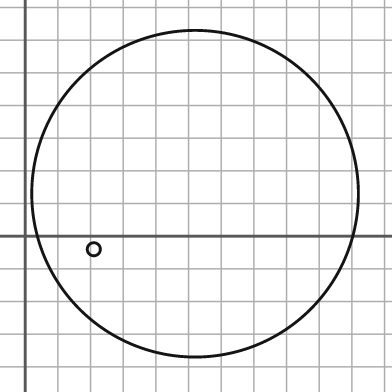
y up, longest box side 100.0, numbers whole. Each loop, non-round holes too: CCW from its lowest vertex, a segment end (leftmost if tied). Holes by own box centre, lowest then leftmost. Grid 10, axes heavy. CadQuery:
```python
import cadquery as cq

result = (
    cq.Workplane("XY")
    .moveTo(52.0, 13.0)
    .circle(50.0)
    .moveTo(21.0, -4.0)
    .circle(2.0)
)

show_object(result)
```